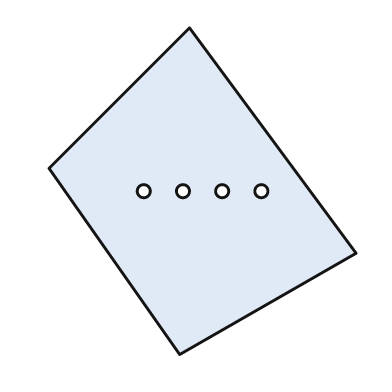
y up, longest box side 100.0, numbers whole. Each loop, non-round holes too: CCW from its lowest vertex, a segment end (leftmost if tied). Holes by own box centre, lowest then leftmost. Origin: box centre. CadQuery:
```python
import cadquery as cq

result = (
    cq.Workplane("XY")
    .moveTo(-7.0, -50.0)
    .lineTo(47.0, -19.0)
    .lineTo(-4.0, 50.0)
    .lineTo(-47.0, 7.0)
    .close()
    .moveTo(-18.0, 0.0)
    .circle(2.0)
    .moveTo(-6.0, 0.0)
    .circle(2.0)
    .moveTo(6.0, 0.0)
    .circle(2.0)
    .moveTo(18.0, 0.0)
    .circle(2.0)
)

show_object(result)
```